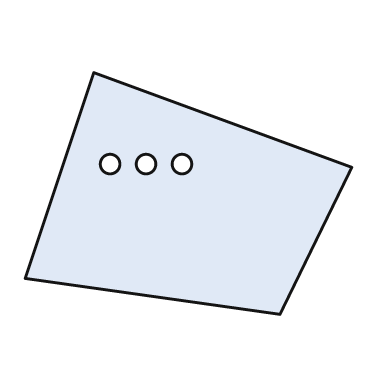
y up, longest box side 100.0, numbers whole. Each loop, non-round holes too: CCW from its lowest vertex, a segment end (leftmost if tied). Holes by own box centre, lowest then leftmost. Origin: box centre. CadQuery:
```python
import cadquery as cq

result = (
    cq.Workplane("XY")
    .moveTo(28.0, -37.0)
    .lineTo(50.0, 8.0)
    .lineTo(-29.0, 37.0)
    .lineTo(-50.0, -26.0)
    .close()
    .moveTo(-24.0, 9.0)
    .circle(3.0)
    .moveTo(-13.0, 9.0)
    .circle(3.0)
    .moveTo(-2.0, 9.0)
    .circle(3.0)
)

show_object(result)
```